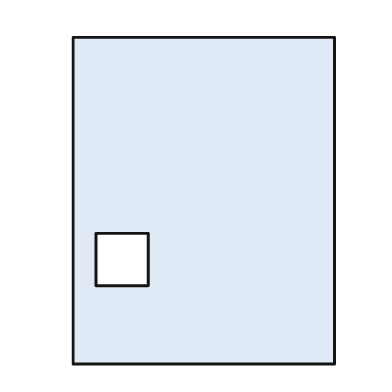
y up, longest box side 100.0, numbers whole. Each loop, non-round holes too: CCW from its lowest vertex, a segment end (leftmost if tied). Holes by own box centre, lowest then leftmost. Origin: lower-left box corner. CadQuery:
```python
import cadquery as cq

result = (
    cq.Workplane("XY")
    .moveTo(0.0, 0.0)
    .lineTo(80.0, 0.0)
    .lineTo(80.0, 100.0)
    .lineTo(0.0, 100.0)
    .close()
    .moveTo(7.0, 24.0)
    .lineTo(23.0, 24.0)
    .lineTo(23.0, 40.0)
    .lineTo(7.0, 40.0)
    .close()
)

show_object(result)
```